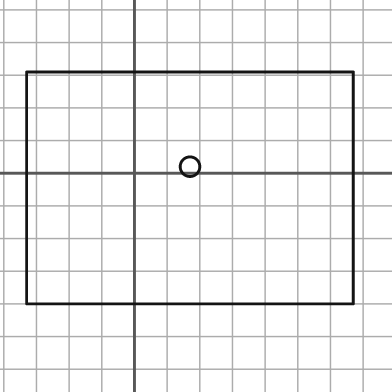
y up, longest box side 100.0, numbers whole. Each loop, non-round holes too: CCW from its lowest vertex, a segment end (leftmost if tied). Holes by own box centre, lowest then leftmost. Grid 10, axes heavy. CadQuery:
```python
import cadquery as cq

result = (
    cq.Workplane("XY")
    .moveTo(-33.0, -40.0)
    .lineTo(67.0, -40.0)
    .lineTo(67.0, 31.0)
    .lineTo(-33.0, 31.0)
    .close()
    .moveTo(17.0, 2.0)
    .circle(3.0)
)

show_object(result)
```